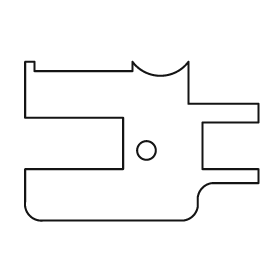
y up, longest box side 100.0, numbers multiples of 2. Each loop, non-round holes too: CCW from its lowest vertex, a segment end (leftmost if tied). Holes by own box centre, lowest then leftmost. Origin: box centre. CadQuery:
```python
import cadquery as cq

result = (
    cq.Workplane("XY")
    .moveTo(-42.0, -34.0)
    .lineTo(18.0, -34.0)
    .threePointArc((22.0, -32.0), (24.0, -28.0))
    .lineTo(24.0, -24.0)
    .threePointArc((26.0, -20.0), (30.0, -18.0))
    .lineTo(50.0, -18.0)
    .lineTo(50.0, -12.0)
    .lineTo(26.0, -12.0)
    .lineTo(26.0, 8.0)
    .lineTo(50.0, 8.0)
    .lineTo(50.0, 16.0)
    .lineTo(20.0, 16.0)
    .lineTo(20.0, 34.0)
    .threePointArc((8.0, 28.0), (-4.0, 34.0))
    .lineTo(-4.0, 30.0)
    .lineTo(-46.0, 30.0)
    .lineTo(-46.0, 34.0)
    .lineTo(-50.0, 34.0)
    .lineTo(-50.0, 10.0)
    .lineTo(-8.0, 10.0)
    .lineTo(-8.0, -12.0)
    .lineTo(-50.0, -12.0)
    .lineTo(-50.0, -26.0)
    .threePointArc((-48.0, -32.0), (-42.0, -34.0))
    .close()
    .moveTo(2.0, -4.0)
    .circle(4.0)
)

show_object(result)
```